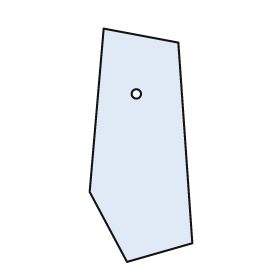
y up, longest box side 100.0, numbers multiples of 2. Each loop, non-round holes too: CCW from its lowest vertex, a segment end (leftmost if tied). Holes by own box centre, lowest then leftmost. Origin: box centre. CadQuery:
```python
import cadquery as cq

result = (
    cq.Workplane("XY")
    .moveTo(-6.0, -50.0)
    .lineTo(22.0, -42.0)
    .lineTo(16.0, 44.0)
    .lineTo(-16.0, 50.0)
    .lineTo(-22.0, -20.0)
    .close()
    .moveTo(-2.0, 22.0)
    .circle(2.0)
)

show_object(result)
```